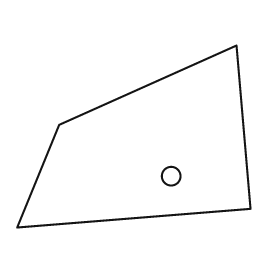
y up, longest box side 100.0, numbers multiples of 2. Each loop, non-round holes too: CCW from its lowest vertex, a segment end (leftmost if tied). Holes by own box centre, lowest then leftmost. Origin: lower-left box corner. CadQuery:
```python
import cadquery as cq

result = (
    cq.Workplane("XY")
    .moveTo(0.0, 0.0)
    .lineTo(100.0, 8.0)
    .lineTo(94.0, 78.0)
    .lineTo(18.0, 44.0)
    .close()
    .moveTo(66.0, 22.0)
    .circle(4.0)
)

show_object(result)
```